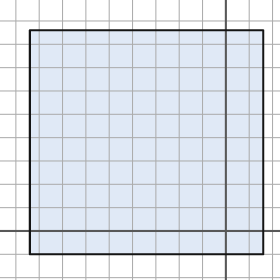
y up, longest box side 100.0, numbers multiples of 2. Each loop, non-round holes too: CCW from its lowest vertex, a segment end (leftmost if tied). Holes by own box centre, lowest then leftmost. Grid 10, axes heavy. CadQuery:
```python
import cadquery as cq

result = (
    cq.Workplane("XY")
    .moveTo(-84.0, -10.0)
    .lineTo(16.0, -10.0)
    .lineTo(16.0, 86.0)
    .lineTo(-84.0, 86.0)
    .close()
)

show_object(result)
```